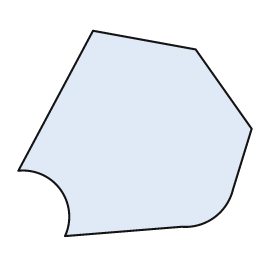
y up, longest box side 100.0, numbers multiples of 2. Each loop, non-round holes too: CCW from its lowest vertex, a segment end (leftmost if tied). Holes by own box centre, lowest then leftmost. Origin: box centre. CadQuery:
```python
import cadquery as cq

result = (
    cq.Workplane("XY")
    .moveTo(-30.0, -44.0)
    .lineTo(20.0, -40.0)
    .threePointArc((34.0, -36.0), (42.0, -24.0))
    .lineTo(50.0, 2.0)
    .lineTo(26.0, 36.0)
    .lineTo(-18.0, 44.0)
    .lineTo(-50.0, -16.0)
    .threePointArc((-32.0, -24.0), (-30.0, -44.0))
    .close()
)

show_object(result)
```